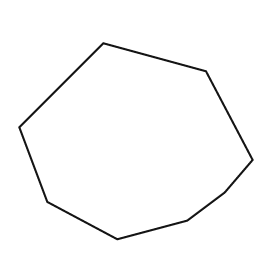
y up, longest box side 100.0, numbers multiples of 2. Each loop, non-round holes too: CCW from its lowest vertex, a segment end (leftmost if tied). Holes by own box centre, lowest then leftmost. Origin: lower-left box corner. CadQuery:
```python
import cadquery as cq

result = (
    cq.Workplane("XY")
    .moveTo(42.0, 0.0)
    .lineTo(72.0, 8.0)
    .lineTo(88.0, 20.0)
    .lineTo(100.0, 34.0)
    .lineTo(80.0, 72.0)
    .lineTo(36.0, 84.0)
    .lineTo(0.0, 48.0)
    .lineTo(12.0, 16.0)
    .close()
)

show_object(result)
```